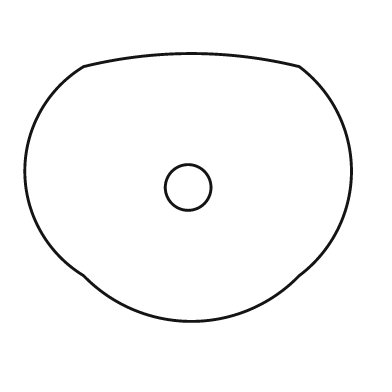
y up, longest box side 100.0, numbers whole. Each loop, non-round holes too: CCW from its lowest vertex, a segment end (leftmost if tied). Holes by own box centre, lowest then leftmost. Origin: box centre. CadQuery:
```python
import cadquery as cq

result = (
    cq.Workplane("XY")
    .moveTo(-32.0, -27.0)
    .threePointArc((1.0, -41.0), (34.0, -27.0))
    .threePointArc((50.0, 5.0), (34.0, 37.0))
    .threePointArc((1.0, 41.0), (-32.0, 37.0))
    .threePointArc((-50.0, 5.0), (-32.0, -27.0))
    .close()
    .moveTo(0.0, 0.0)
    .circle(7.0)
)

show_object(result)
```